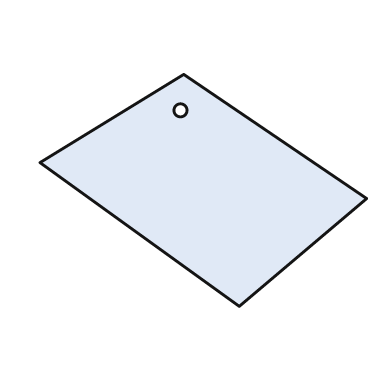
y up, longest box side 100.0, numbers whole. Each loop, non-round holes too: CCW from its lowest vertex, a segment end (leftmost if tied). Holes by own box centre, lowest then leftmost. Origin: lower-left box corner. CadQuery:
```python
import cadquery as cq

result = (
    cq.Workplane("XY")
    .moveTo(61.0, 0.0)
    .lineTo(100.0, 33.0)
    .lineTo(44.0, 71.0)
    .lineTo(0.0, 44.0)
    .close()
    .moveTo(43.0, 60.0)
    .circle(2.0)
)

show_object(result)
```